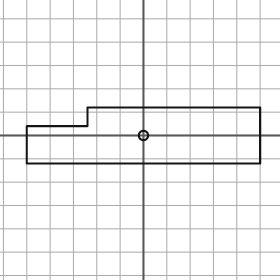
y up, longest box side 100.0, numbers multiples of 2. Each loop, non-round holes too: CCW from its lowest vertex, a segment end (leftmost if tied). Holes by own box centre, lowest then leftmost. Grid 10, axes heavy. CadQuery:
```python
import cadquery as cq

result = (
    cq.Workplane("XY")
    .moveTo(-50.0, -12.0)
    .lineTo(50.0, -12.0)
    .lineTo(50.0, 12.0)
    .lineTo(-24.0, 12.0)
    .lineTo(-24.0, 4.0)
    .lineTo(-50.0, 4.0)
    .close()
    .moveTo(0.0, 0.0)
    .circle(2.0)
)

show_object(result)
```